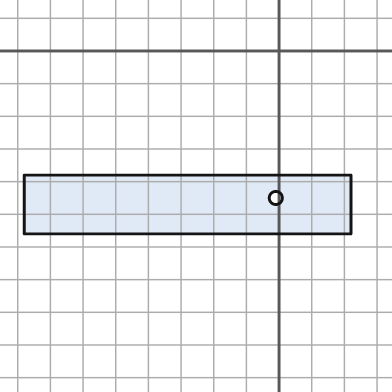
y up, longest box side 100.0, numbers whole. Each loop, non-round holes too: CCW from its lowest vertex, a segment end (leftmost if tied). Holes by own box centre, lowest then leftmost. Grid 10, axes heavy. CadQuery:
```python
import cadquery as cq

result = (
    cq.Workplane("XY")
    .moveTo(-78.0, -56.0)
    .lineTo(22.0, -56.0)
    .lineTo(22.0, -38.0)
    .lineTo(-78.0, -38.0)
    .close()
    .moveTo(-1.0, -45.0)
    .circle(2.0)
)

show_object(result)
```